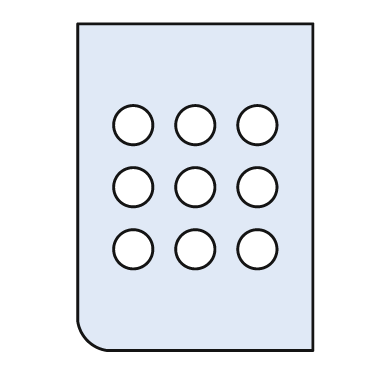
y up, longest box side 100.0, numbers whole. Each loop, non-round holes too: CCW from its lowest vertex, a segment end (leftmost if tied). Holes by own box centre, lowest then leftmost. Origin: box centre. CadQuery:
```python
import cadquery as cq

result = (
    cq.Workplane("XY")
    .moveTo(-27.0, -50.0)
    .lineTo(36.0, -50.0)
    .lineTo(36.0, 50.0)
    .lineTo(-36.0, 50.0)
    .lineTo(-36.0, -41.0)
    .threePointArc((-33.0, -47.0), (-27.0, -50.0))
    .close()
    .moveTo(-19.0, -19.0)
    .circle(6.0)
    .moveTo(0.0, -19.0)
    .circle(6.0)
    .moveTo(19.0, -19.0)
    .circle(6.0)
    .moveTo(-19.0, 0.0)
    .circle(6.0)
    .moveTo(0.0, 0.0)
    .circle(6.0)
    .moveTo(19.0, 0.0)
    .circle(6.0)
    .moveTo(-19.0, 19.0)
    .circle(6.0)
    .moveTo(0.0, 19.0)
    .circle(6.0)
    .moveTo(19.0, 19.0)
    .circle(6.0)
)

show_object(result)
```